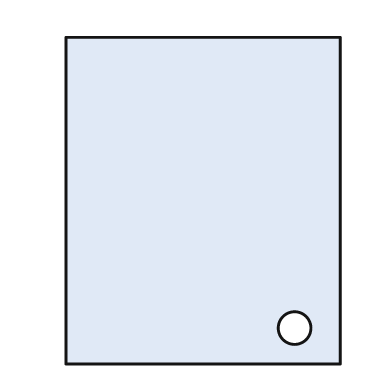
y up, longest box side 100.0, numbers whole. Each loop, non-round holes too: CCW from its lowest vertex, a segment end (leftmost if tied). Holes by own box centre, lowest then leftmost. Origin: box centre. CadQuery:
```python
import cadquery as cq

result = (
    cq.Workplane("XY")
    .moveTo(-42.0, -50.0)
    .lineTo(42.0, -50.0)
    .lineTo(42.0, 50.0)
    .lineTo(-42.0, 50.0)
    .close()
    .moveTo(28.0, -39.0)
    .circle(5.0)
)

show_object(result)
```